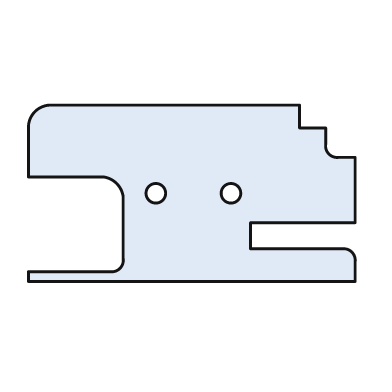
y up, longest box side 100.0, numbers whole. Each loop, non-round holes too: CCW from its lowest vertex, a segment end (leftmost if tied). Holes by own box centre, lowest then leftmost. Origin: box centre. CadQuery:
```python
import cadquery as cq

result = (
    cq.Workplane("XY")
    .moveTo(-50.0, -27.0)
    .lineTo(50.0, -27.0)
    .lineTo(50.0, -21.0)
    .threePointArc((49.0, -18.0), (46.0, -17.0))
    .lineTo(18.0, -17.0)
    .lineTo(18.0, -9.0)
    .lineTo(50.0, -9.0)
    .lineTo(50.0, 11.0)
    .lineTo(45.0, 11.0)
    .threePointArc((42.0, 12.0), (41.0, 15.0))
    .lineTo(41.0, 20.0)
    .lineTo(33.0, 20.0)
    .lineTo(33.0, 27.0)
    .lineTo(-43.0, 27.0)
    .threePointArc((-48.0, 25.0), (-50.0, 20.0))
    .lineTo(-50.0, 5.0)
    .lineTo(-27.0, 5.0)
    .threePointArc((-23.0, 3.0), (-21.0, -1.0))
    .lineTo(-21.0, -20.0)
    .threePointArc((-22.0, -23.0), (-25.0, -24.0))
    .lineTo(-50.0, -24.0)
    .close()
    .moveTo(-11.0, 0.0)
    .circle(3.0)
    .moveTo(12.0, 0.0)
    .circle(3.0)
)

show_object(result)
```